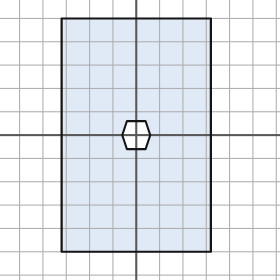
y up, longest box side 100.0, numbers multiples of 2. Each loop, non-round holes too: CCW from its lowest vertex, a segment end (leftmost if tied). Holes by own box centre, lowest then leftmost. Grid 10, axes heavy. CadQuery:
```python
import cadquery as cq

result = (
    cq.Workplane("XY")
    .moveTo(-32.0, -50.0)
    .lineTo(32.0, -50.0)
    .lineTo(32.0, 50.0)
    .lineTo(-32.0, 50.0)
    .close()
    .moveTo(-4.0, -6.0)
    .lineTo(4.0, -6.0)
    .lineTo(6.0, 0.0)
    .lineTo(4.0, 6.0)
    .lineTo(-4.0, 6.0)
    .lineTo(-6.0, 0.0)
    .close()
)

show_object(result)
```